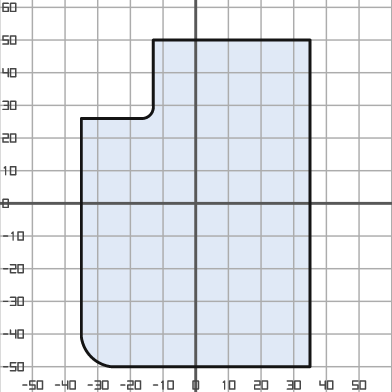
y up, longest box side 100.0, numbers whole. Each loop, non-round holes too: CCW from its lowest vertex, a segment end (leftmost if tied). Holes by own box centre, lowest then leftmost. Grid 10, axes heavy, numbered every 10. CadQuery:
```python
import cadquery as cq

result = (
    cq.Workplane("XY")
    .moveTo(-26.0, -50.0)
    .lineTo(35.0, -50.0)
    .lineTo(35.0, 50.0)
    .lineTo(-13.0, 50.0)
    .lineTo(-13.0, 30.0)
    .threePointArc((-14.0, 27.0), (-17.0, 26.0))
    .lineTo(-35.0, 26.0)
    .lineTo(-35.0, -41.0)
    .threePointArc((-32.0, -47.0), (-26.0, -50.0))
    .close()
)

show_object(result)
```